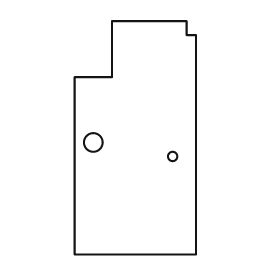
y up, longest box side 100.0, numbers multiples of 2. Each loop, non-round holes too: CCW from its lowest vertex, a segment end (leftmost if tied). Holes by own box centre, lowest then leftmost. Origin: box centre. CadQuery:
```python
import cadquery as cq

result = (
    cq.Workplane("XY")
    .moveTo(-26.0, -50.0)
    .lineTo(26.0, -50.0)
    .lineTo(26.0, 44.0)
    .lineTo(22.0, 44.0)
    .lineTo(22.0, 50.0)
    .lineTo(-10.0, 50.0)
    .lineTo(-10.0, 26.0)
    .lineTo(-26.0, 26.0)
    .close()
    .moveTo(16.0, -8.0)
    .circle(2.0)
    .moveTo(-18.0, -2.0)
    .circle(4.0)
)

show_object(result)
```